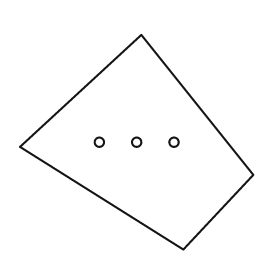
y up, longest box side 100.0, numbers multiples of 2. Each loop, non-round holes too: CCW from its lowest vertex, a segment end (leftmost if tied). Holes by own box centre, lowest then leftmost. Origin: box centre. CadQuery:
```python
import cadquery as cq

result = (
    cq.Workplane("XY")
    .moveTo(20.0, -46.0)
    .lineTo(50.0, -14.0)
    .lineTo(2.0, 46.0)
    .lineTo(-50.0, -2.0)
    .close()
    .moveTo(-16.0, 0.0)
    .circle(2.0)
    .moveTo(0.0, 0.0)
    .circle(2.0)
    .moveTo(16.0, 0.0)
    .circle(2.0)
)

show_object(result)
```